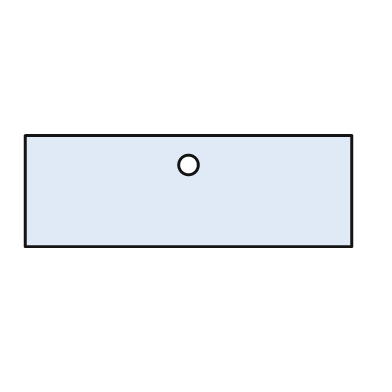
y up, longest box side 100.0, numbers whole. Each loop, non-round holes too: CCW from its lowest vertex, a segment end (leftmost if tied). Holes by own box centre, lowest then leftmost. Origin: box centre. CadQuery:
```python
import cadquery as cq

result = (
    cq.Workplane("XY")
    .moveTo(-50.0, -17.0)
    .lineTo(50.0, -17.0)
    .lineTo(50.0, 17.0)
    .lineTo(-50.0, 17.0)
    .close()
    .moveTo(0.0, 8.0)
    .circle(3.0)
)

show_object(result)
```